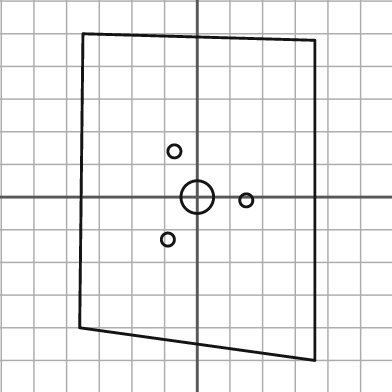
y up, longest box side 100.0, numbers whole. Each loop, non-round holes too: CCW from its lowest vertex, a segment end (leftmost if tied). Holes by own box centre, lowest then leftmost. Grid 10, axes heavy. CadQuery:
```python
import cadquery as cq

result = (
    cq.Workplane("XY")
    .moveTo(36.0, -50.0)
    .lineTo(36.0, 48.0)
    .lineTo(-35.0, 50.0)
    .lineTo(-36.0, -40.0)
    .close()
    .moveTo(-9.0, -13.0)
    .circle(2.0)
    .moveTo(15.0, -1.0)
    .circle(2.0)
    .moveTo(0.0, 0.0)
    .circle(5.0)
    .moveTo(-7.0, 14.0)
    .circle(2.0)
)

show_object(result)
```